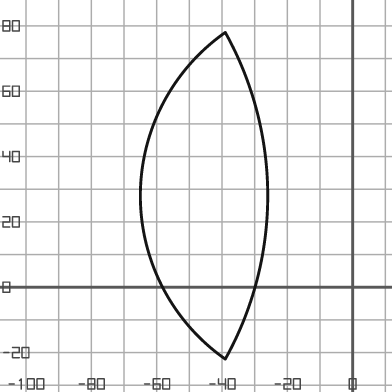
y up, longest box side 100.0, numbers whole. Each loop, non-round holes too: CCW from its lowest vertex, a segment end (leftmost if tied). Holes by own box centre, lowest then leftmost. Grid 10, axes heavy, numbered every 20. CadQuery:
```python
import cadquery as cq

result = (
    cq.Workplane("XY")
    .moveTo(-39.0, -22.0)
    .threePointArc((-26.0, 28.0), (-39.0, 78.0))
    .threePointArc((-65.0, 28.0), (-39.0, -22.0))
    .close()
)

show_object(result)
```